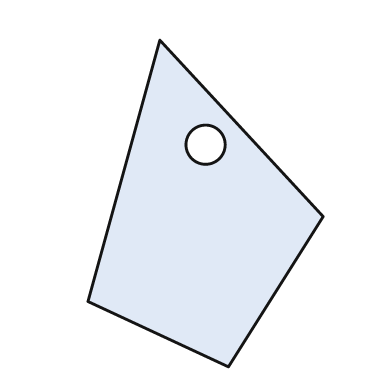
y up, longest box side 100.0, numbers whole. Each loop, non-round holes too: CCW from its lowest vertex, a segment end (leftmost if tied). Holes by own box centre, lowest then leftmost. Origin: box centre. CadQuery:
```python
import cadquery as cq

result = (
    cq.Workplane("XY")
    .moveTo(7.0, -50.0)
    .lineTo(36.0, -4.0)
    .lineTo(-14.0, 50.0)
    .lineTo(-36.0, -30.0)
    .close()
    .moveTo(0.0, 18.0)
    .circle(6.0)
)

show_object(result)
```